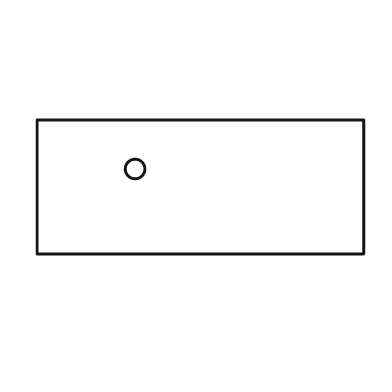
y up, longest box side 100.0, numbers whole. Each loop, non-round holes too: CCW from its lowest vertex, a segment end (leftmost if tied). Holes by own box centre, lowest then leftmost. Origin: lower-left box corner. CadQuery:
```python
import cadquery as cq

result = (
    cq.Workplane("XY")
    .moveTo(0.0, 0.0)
    .lineTo(100.0, 0.0)
    .lineTo(100.0, 41.0)
    .lineTo(0.0, 41.0)
    .close()
    .moveTo(30.0, 26.0)
    .circle(3.0)
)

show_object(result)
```